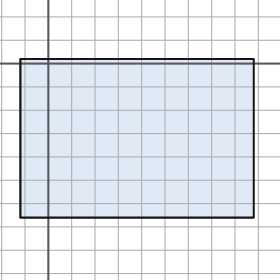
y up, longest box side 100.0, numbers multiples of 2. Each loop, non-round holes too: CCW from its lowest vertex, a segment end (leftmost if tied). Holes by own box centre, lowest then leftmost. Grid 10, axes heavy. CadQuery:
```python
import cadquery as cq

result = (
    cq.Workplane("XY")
    .moveTo(-12.0, -66.0)
    .lineTo(88.0, -66.0)
    .lineTo(88.0, 2.0)
    .lineTo(-12.0, 2.0)
    .close()
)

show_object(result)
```